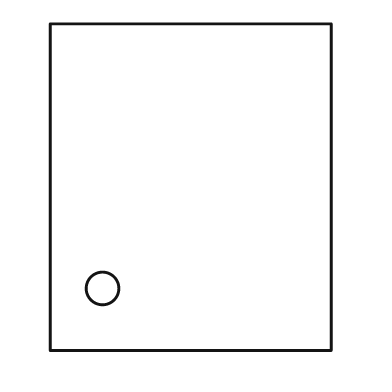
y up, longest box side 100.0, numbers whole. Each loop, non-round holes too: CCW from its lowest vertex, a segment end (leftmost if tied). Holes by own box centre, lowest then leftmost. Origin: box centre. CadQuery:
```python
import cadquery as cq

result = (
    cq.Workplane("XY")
    .moveTo(-43.0, -50.0)
    .lineTo(43.0, -50.0)
    .lineTo(43.0, 50.0)
    .lineTo(-43.0, 50.0)
    .close()
    .moveTo(-27.0, -31.0)
    .circle(5.0)
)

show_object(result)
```